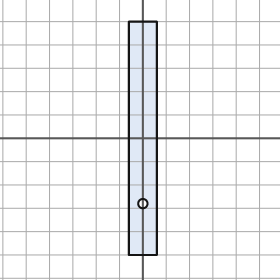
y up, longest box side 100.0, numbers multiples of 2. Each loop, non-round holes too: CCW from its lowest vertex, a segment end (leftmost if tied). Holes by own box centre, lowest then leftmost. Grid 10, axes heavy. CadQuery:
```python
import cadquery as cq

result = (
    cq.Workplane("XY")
    .moveTo(-6.0, -50.0)
    .lineTo(6.0, -50.0)
    .lineTo(6.0, 50.0)
    .lineTo(-6.0, 50.0)
    .close()
    .moveTo(0.0, -28.0)
    .circle(2.0)
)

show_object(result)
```